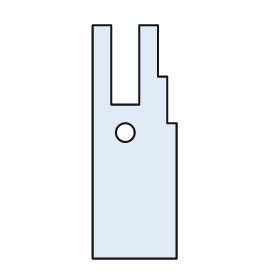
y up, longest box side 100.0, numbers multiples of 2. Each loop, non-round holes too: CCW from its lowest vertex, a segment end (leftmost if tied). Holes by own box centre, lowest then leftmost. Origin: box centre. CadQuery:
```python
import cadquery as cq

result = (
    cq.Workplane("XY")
    .moveTo(-18.0, -50.0)
    .lineTo(18.0, -50.0)
    .lineTo(18.0, 8.0)
    .lineTo(14.0, 8.0)
    .lineTo(14.0, 28.0)
    .lineTo(10.0, 28.0)
    .lineTo(10.0, 50.0)
    .lineTo(2.0, 50.0)
    .lineTo(2.0, 16.0)
    .lineTo(-10.0, 16.0)
    .lineTo(-10.0, 50.0)
    .lineTo(-18.0, 50.0)
    .close()
    .moveTo(-4.0, 4.0)
    .circle(4.0)
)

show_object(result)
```